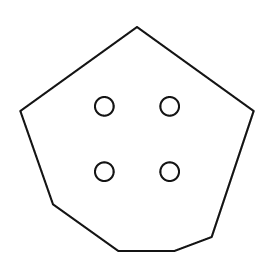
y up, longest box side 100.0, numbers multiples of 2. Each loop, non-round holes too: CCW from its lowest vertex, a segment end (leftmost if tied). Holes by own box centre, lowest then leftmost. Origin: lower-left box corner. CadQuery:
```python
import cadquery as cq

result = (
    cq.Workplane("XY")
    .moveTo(42.0, 0.0)
    .lineTo(66.0, 0.0)
    .lineTo(82.0, 6.0)
    .lineTo(100.0, 60.0)
    .lineTo(50.0, 96.0)
    .lineTo(0.0, 60.0)
    .lineTo(14.0, 20.0)
    .close()
    .moveTo(36.0, 34.0)
    .circle(4.0)
    .moveTo(64.0, 34.0)
    .circle(4.0)
    .moveTo(36.0, 62.0)
    .circle(4.0)
    .moveTo(64.0, 62.0)
    .circle(4.0)
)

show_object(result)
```